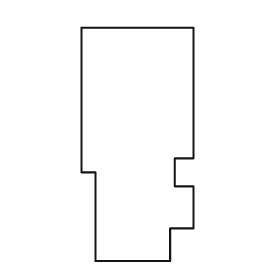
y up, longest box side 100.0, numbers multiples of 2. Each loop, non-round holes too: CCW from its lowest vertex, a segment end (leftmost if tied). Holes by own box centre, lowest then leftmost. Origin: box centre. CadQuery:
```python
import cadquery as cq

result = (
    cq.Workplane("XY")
    .moveTo(-18.0, -50.0)
    .lineTo(14.0, -50.0)
    .lineTo(14.0, -36.0)
    .lineTo(24.0, -36.0)
    .lineTo(24.0, -18.0)
    .lineTo(16.0, -18.0)
    .lineTo(16.0, -6.0)
    .lineTo(24.0, -6.0)
    .lineTo(24.0, 50.0)
    .lineTo(-24.0, 50.0)
    .lineTo(-24.0, -12.0)
    .lineTo(-18.0, -12.0)
    .close()
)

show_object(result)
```